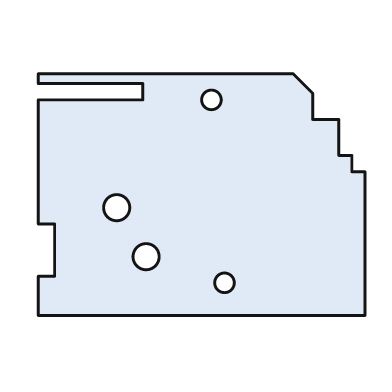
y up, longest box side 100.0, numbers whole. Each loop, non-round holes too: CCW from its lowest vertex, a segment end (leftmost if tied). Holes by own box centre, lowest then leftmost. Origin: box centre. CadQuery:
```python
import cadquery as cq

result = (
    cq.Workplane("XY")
    .moveTo(-50.0, -37.0)
    .lineTo(50.0, -37.0)
    .lineTo(50.0, 7.0)
    .lineTo(46.0, 7.0)
    .lineTo(46.0, 12.0)
    .lineTo(42.0, 12.0)
    .lineTo(42.0, 23.0)
    .lineTo(34.0, 23.0)
    .lineTo(34.0, 31.0)
    .lineTo(28.0, 37.0)
    .lineTo(-50.0, 37.0)
    .lineTo(-50.0, 34.0)
    .lineTo(-18.0, 34.0)
    .lineTo(-18.0, 29.0)
    .lineTo(-50.0, 29.0)
    .lineTo(-50.0, -9.0)
    .lineTo(-45.0, -9.0)
    .lineTo(-45.0, -25.0)
    .lineTo(-50.0, -25.0)
    .close()
    .moveTo(7.0, -27.0)
    .circle(3.0)
    .moveTo(-17.0, -19.0)
    .circle(4.0)
    .moveTo(-26.0, -4.0)
    .circle(4.0)
    .moveTo(3.0, 29.0)
    .circle(3.0)
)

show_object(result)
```